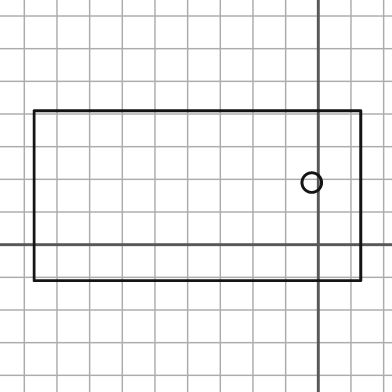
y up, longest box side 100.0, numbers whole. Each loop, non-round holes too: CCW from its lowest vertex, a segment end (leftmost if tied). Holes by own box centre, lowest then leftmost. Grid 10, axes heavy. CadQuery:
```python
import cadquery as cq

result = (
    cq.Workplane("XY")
    .moveTo(-87.0, -11.0)
    .lineTo(13.0, -11.0)
    .lineTo(13.0, 41.0)
    .lineTo(-87.0, 41.0)
    .close()
    .moveTo(-2.0, 19.0)
    .circle(3.0)
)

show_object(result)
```